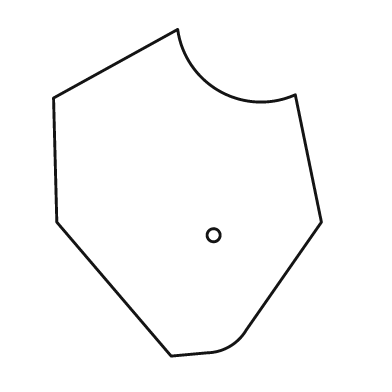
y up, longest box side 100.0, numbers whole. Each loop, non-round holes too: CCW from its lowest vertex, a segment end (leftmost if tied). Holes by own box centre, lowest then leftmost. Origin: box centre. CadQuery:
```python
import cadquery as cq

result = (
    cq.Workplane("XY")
    .moveTo(-5.0, -50.0)
    .lineTo(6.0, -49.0)
    .threePointArc((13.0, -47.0), (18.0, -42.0))
    .lineTo(41.0, -9.0)
    .lineTo(33.0, 30.0)
    .threePointArc((10.0, 31.0), (-3.0, 50.0))
    .lineTo(-41.0, 29.0)
    .lineTo(-40.0, -9.0)
    .close()
    .moveTo(8.0, -13.0)
    .circle(2.0)
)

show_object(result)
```